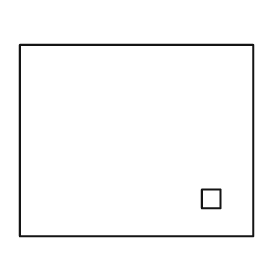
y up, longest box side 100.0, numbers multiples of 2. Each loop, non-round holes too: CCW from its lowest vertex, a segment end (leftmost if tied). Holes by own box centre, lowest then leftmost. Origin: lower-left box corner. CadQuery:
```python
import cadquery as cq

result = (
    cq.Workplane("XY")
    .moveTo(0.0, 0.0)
    .lineTo(100.0, 0.0)
    .lineTo(100.0, 82.0)
    .lineTo(0.0, 82.0)
    .close()
    .moveTo(78.0, 12.0)
    .lineTo(86.0, 12.0)
    .lineTo(86.0, 20.0)
    .lineTo(78.0, 20.0)
    .close()
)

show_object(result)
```